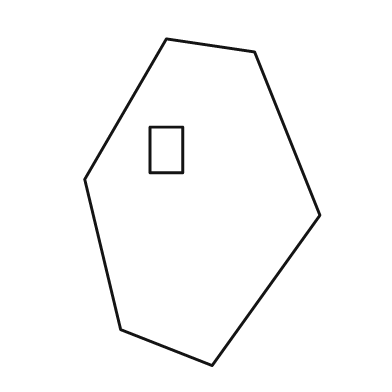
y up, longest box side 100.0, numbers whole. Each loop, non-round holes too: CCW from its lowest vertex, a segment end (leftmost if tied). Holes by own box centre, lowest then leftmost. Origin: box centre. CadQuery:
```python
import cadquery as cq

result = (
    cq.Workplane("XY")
    .moveTo(3.0, -50.0)
    .lineTo(36.0, -4.0)
    .lineTo(16.0, 46.0)
    .lineTo(-11.0, 50.0)
    .lineTo(-36.0, 7.0)
    .lineTo(-25.0, -39.0)
    .close()
    .moveTo(-16.0, 9.0)
    .lineTo(-6.0, 9.0)
    .lineTo(-6.0, 23.0)
    .lineTo(-16.0, 23.0)
    .close()
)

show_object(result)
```